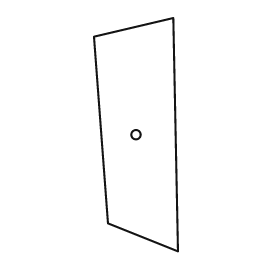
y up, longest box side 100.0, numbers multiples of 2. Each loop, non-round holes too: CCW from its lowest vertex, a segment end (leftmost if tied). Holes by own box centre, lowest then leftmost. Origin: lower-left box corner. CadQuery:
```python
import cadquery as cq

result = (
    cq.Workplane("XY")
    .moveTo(36.0, 0.0)
    .lineTo(34.0, 100.0)
    .lineTo(0.0, 92.0)
    .lineTo(6.0, 12.0)
    .close()
    .moveTo(18.0, 50.0)
    .circle(2.0)
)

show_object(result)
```